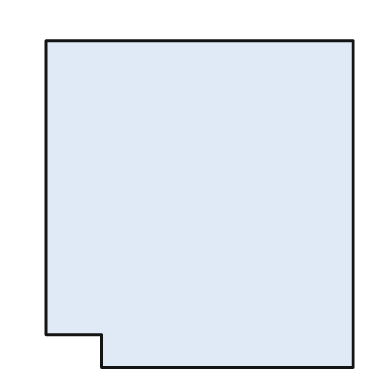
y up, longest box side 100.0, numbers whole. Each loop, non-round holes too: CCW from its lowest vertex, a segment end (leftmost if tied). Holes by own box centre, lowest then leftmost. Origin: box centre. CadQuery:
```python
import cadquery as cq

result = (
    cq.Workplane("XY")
    .moveTo(-30.0, -50.0)
    .lineTo(47.0, -50.0)
    .lineTo(47.0, 50.0)
    .lineTo(-47.0, 50.0)
    .lineTo(-47.0, -40.0)
    .lineTo(-30.0, -40.0)
    .close()
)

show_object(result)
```